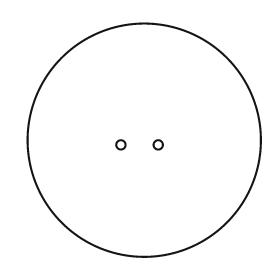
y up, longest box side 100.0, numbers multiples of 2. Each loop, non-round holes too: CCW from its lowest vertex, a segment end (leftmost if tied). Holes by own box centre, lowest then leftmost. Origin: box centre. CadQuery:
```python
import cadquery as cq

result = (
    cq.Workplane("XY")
    .moveTo(0.0, 0.0)
    .circle(50.0)
    .moveTo(-10.0, -2.0)
    .circle(2.0)
    .moveTo(6.0, -2.0)
    .circle(2.0)
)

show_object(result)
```